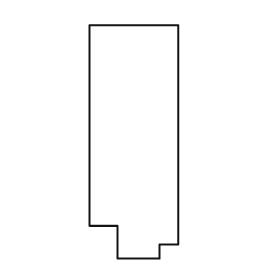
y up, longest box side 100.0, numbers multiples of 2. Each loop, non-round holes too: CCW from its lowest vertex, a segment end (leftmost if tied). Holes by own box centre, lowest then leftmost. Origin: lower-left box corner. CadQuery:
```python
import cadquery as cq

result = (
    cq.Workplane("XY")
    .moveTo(12.0, 0.0)
    .lineTo(30.0, 0.0)
    .lineTo(30.0, 6.0)
    .lineTo(38.0, 6.0)
    .lineTo(38.0, 100.0)
    .lineTo(0.0, 100.0)
    .lineTo(0.0, 14.0)
    .lineTo(12.0, 14.0)
    .close()
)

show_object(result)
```